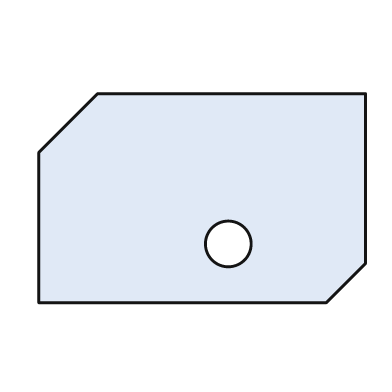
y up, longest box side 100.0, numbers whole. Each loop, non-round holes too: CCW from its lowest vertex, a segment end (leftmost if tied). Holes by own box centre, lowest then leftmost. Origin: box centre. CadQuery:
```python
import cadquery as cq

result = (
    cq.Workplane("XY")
    .moveTo(-50.0, -32.0)
    .lineTo(38.0, -32.0)
    .lineTo(50.0, -20.0)
    .lineTo(50.0, 32.0)
    .lineTo(-32.0, 32.0)
    .lineTo(-50.0, 14.0)
    .close()
    .moveTo(8.0, -14.0)
    .circle(7.0)
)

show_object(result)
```